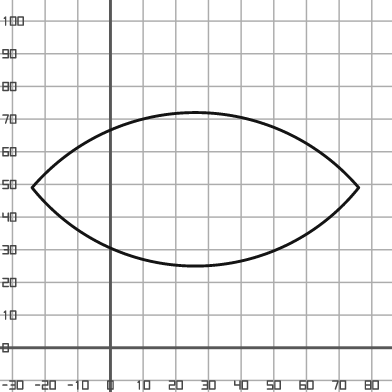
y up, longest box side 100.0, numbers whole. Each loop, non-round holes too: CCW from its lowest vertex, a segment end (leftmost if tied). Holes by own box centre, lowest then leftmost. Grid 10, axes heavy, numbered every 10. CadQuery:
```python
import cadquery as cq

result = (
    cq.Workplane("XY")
    .moveTo(-24.0, 49.0)
    .threePointArc((26.0, 25.0), (76.0, 49.0))
    .threePointArc((26.0, 72.0), (-24.0, 49.0))
    .close()
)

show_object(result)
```